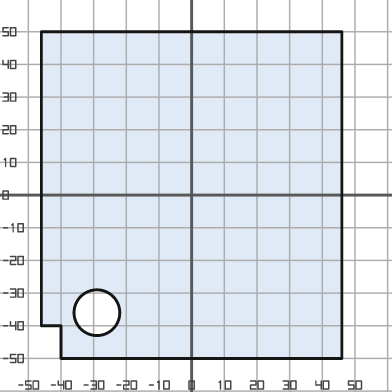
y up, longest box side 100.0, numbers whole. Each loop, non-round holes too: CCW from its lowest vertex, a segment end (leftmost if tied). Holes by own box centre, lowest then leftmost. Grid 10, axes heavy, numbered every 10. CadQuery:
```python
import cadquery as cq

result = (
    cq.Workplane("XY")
    .moveTo(-40.0, -50.0)
    .lineTo(46.0, -50.0)
    .lineTo(46.0, 50.0)
    .lineTo(-46.0, 50.0)
    .lineTo(-46.0, -40.0)
    .lineTo(-40.0, -40.0)
    .close()
    .moveTo(-29.0, -36.0)
    .circle(7.0)
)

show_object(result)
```